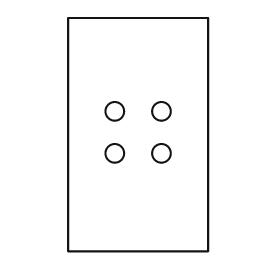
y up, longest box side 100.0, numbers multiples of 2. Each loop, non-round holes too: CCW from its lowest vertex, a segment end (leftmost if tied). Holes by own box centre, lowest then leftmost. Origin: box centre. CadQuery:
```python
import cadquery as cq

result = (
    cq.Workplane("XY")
    .moveTo(-30.0, -50.0)
    .lineTo(30.0, -50.0)
    .lineTo(30.0, 50.0)
    .lineTo(-30.0, 50.0)
    .close()
    .moveTo(-10.0, -8.0)
    .circle(4.0)
    .moveTo(10.0, -8.0)
    .circle(4.0)
    .moveTo(-10.0, 10.0)
    .circle(4.0)
    .moveTo(10.0, 10.0)
    .circle(4.0)
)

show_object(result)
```